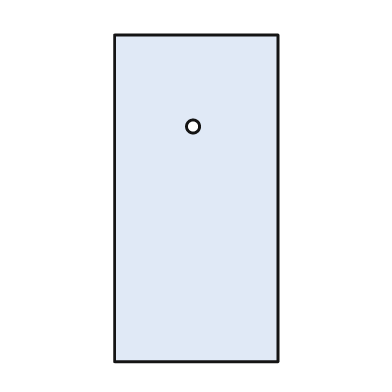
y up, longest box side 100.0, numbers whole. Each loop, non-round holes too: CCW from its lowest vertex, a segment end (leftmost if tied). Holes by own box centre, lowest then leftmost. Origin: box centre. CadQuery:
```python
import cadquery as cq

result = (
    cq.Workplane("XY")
    .moveTo(-25.0, -50.0)
    .lineTo(25.0, -50.0)
    .lineTo(25.0, 50.0)
    .lineTo(-25.0, 50.0)
    .close()
    .moveTo(-1.0, 22.0)
    .circle(2.0)
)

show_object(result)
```